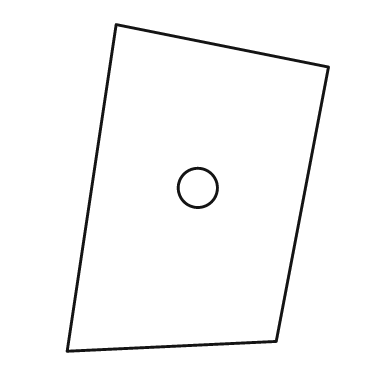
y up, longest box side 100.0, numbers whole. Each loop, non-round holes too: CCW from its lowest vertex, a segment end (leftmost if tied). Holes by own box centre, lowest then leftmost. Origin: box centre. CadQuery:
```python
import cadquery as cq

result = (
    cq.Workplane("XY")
    .moveTo(-40.0, -50.0)
    .lineTo(24.0, -47.0)
    .lineTo(40.0, 37.0)
    .lineTo(-25.0, 50.0)
    .close()
    .moveTo(0.0, 0.0)
    .circle(6.0)
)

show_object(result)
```